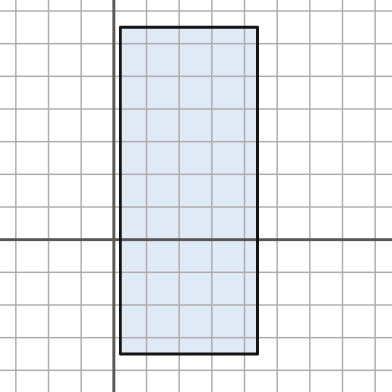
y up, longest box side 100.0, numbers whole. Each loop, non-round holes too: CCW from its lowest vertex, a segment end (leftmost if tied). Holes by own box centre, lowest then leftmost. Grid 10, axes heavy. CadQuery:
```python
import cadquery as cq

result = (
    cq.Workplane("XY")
    .moveTo(2.0, -35.0)
    .lineTo(44.0, -35.0)
    .lineTo(44.0, 65.0)
    .lineTo(2.0, 65.0)
    .close()
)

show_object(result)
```